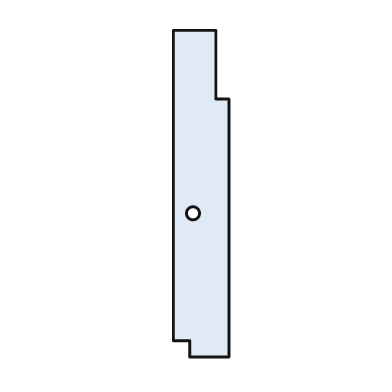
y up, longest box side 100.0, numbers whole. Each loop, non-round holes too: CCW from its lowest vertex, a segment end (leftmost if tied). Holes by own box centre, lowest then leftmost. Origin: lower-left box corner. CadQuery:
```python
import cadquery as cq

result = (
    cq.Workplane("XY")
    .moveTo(5.0, 0.0)
    .lineTo(17.0, 0.0)
    .lineTo(17.0, 79.0)
    .lineTo(13.0, 79.0)
    .lineTo(13.0, 100.0)
    .lineTo(0.0, 100.0)
    .lineTo(0.0, 5.0)
    .lineTo(5.0, 5.0)
    .close()
    .moveTo(6.0, 44.0)
    .circle(2.0)
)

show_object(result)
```